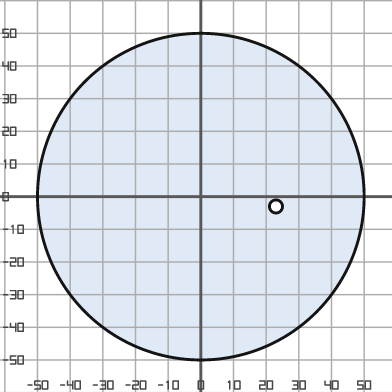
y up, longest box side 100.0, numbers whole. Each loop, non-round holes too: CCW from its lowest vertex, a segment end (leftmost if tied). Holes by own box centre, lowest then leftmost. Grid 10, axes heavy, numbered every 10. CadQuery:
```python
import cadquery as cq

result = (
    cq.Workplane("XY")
    .moveTo(0.0, 0.0)
    .circle(50.0)
    .moveTo(23.0, -3.0)
    .circle(2.0)
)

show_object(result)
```